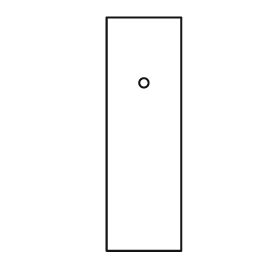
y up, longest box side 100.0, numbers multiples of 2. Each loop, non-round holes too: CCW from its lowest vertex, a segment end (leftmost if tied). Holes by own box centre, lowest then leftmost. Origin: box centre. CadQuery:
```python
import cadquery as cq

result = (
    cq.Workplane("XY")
    .moveTo(-16.0, -50.0)
    .lineTo(16.0, -50.0)
    .lineTo(16.0, 50.0)
    .lineTo(-16.0, 50.0)
    .close()
    .moveTo(0.0, 22.0)
    .circle(2.0)
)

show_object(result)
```